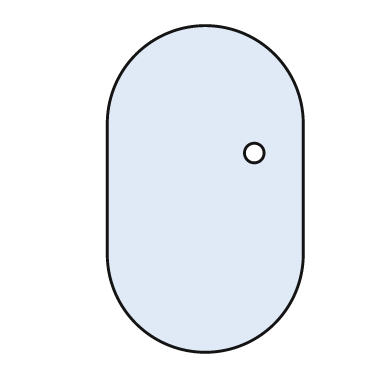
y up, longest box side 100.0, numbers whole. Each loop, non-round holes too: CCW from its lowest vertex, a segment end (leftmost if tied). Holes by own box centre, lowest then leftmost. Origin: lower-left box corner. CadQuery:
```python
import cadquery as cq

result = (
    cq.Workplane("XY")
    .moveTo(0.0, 30.0)
    .threePointArc((30.0, 0.0), (60.0, 30.0))
    .lineTo(60.0, 70.0)
    .threePointArc((30.0, 100.0), (0.0, 70.0))
    .close()
    .moveTo(45.0, 61.0)
    .circle(3.0)
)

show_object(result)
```